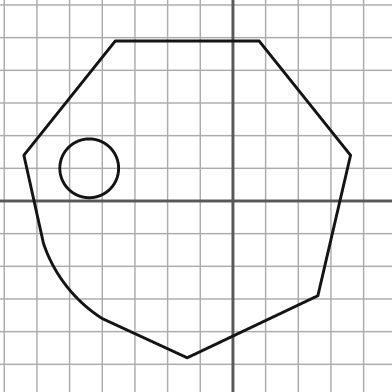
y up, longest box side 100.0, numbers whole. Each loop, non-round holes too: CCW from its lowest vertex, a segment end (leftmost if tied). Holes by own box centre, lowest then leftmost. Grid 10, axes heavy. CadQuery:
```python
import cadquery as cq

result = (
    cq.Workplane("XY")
    .moveTo(-14.0, -48.0)
    .lineTo(26.0, -29.0)
    .lineTo(36.0, 14.0)
    .lineTo(8.0, 49.0)
    .lineTo(-36.0, 49.0)
    .lineTo(-64.0, 14.0)
    .lineTo(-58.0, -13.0)
    .threePointArc((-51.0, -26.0), (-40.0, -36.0))
    .close()
    .moveTo(-44.0, 10.0)
    .circle(9.0)
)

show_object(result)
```